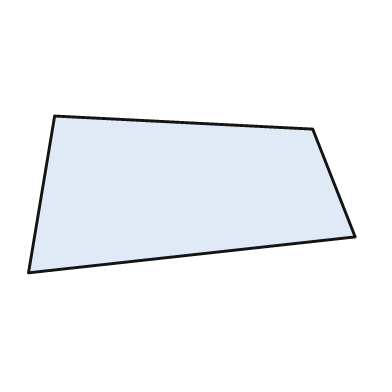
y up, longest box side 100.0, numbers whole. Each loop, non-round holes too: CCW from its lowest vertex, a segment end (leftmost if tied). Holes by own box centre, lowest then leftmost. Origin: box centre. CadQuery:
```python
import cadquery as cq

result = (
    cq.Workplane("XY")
    .moveTo(-50.0, -24.0)
    .lineTo(50.0, -13.0)
    .lineTo(37.0, 20.0)
    .lineTo(-42.0, 24.0)
    .close()
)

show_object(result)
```